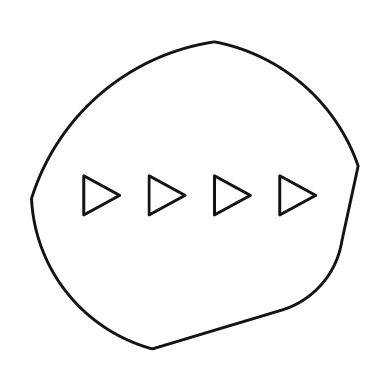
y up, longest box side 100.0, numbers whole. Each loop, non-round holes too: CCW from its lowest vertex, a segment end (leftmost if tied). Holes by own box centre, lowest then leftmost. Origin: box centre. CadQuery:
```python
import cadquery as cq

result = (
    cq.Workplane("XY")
    .moveTo(-13.0, -47.0)
    .lineTo(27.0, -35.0)
    .threePointArc((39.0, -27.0), (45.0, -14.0))
    .lineTo(50.0, 9.0)
    .threePointArc((33.0, 34.0), (6.0, 47.0))
    .threePointArc((-29.0, 31.0), (-50.0, -1.0))
    .threePointArc((-39.0, -30.0), (-13.0, -47.0))
    .close()
    .moveTo(-34.0, -6.0)
    .lineTo(-23.0, 0.0)
    .lineTo(-34.0, 6.0)
    .close()
    .moveTo(-14.0, -6.0)
    .lineTo(-3.0, 0.0)
    .lineTo(-14.0, 6.0)
    .close()
    .moveTo(6.0, -6.0)
    .lineTo(17.0, 0.0)
    .lineTo(6.0, 6.0)
    .close()
    .moveTo(26.0, -6.0)
    .lineTo(37.0, 0.0)
    .lineTo(26.0, 6.0)
    .close()
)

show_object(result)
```